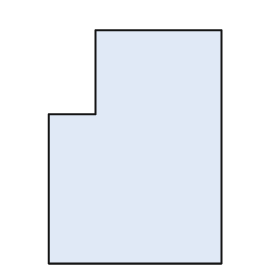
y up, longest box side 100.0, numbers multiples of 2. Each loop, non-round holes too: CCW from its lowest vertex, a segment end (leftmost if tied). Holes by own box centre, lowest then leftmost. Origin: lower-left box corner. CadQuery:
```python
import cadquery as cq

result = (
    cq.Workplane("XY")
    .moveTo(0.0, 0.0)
    .lineTo(74.0, 0.0)
    .lineTo(74.0, 100.0)
    .lineTo(20.0, 100.0)
    .lineTo(20.0, 64.0)
    .lineTo(0.0, 64.0)
    .close()
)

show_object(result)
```